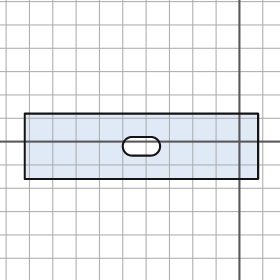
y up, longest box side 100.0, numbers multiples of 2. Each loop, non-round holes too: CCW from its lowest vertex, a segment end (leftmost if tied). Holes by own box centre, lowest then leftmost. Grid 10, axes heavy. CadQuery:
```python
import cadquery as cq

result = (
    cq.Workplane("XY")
    .moveTo(-92.0, -16.0)
    .lineTo(8.0, -16.0)
    .lineTo(8.0, 12.0)
    .lineTo(-92.0, 12.0)
    .close()
    .moveTo(-46.0, -6.0)
    .lineTo(-38.0, -6.0)
    .threePointArc((-34.0, -2.0), (-38.0, 2.0))
    .lineTo(-46.0, 2.0)
    .threePointArc((-50.0, -2.0), (-46.0, -6.0))
    .close()
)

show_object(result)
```